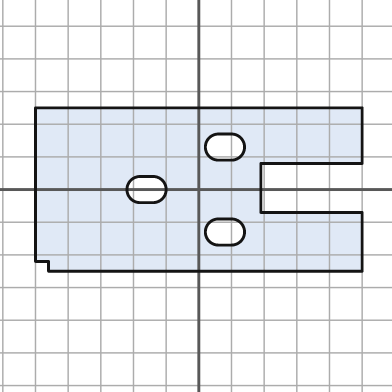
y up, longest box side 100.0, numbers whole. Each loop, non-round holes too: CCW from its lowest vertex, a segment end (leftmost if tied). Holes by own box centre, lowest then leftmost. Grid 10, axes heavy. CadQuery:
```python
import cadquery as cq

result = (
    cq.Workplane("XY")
    .moveTo(-46.0, -25.0)
    .lineTo(50.0, -25.0)
    .lineTo(50.0, -7.0)
    .lineTo(19.0, -7.0)
    .lineTo(19.0, 8.0)
    .lineTo(50.0, 8.0)
    .lineTo(50.0, 25.0)
    .lineTo(-50.0, 25.0)
    .lineTo(-50.0, -22.0)
    .lineTo(-46.0, -22.0)
    .close()
    .moveTo(6.0, -17.0)
    .lineTo(10.0, -17.0)
    .threePointArc((14.0, -13.0), (10.0, -9.0))
    .lineTo(6.0, -9.0)
    .threePointArc((2.0, -13.0), (6.0, -17.0))
    .close()
    .moveTo(-18.0, -4.0)
    .lineTo(-14.0, -4.0)
    .threePointArc((-10.0, 0.0), (-14.0, 4.0))
    .lineTo(-18.0, 4.0)
    .threePointArc((-22.0, 0.0), (-18.0, -4.0))
    .close()
    .moveTo(6.0, 9.0)
    .lineTo(10.0, 9.0)
    .threePointArc((14.0, 13.0), (10.0, 17.0))
    .lineTo(6.0, 17.0)
    .threePointArc((2.0, 13.0), (6.0, 9.0))
    .close()
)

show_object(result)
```